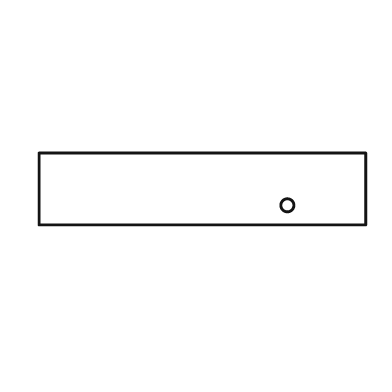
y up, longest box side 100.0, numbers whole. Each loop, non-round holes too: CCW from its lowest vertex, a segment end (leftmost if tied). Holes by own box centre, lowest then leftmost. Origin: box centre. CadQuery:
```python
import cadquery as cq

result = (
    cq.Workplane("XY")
    .moveTo(-50.0, -11.0)
    .lineTo(50.0, -11.0)
    .lineTo(50.0, 11.0)
    .lineTo(-50.0, 11.0)
    .close()
    .moveTo(26.0, -5.0)
    .circle(2.0)
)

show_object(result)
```